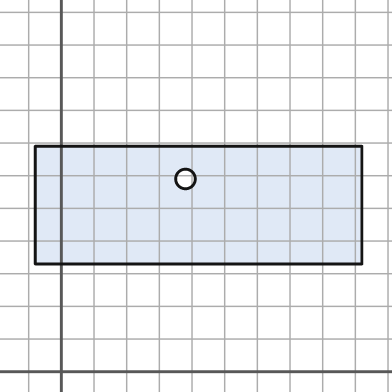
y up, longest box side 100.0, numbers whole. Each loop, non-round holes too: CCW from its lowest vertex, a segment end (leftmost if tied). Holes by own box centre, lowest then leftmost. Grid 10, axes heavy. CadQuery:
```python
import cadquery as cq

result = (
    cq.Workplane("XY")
    .moveTo(-8.0, 33.0)
    .lineTo(92.0, 33.0)
    .lineTo(92.0, 69.0)
    .lineTo(-8.0, 69.0)
    .close()
    .moveTo(38.0, 59.0)
    .circle(3.0)
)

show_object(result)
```